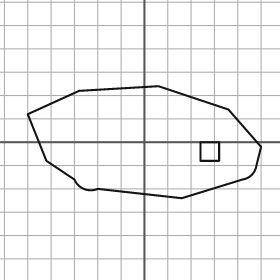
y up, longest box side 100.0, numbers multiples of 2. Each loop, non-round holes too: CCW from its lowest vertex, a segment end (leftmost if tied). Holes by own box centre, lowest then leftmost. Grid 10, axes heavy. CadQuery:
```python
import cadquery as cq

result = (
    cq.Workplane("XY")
    .moveTo(16.0, -24.0)
    .lineTo(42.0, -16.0)
    .threePointArc((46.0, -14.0), (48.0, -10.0))
    .lineTo(50.0, -2.0)
    .lineTo(36.0, 14.0)
    .lineTo(6.0, 24.0)
    .lineTo(-28.0, 22.0)
    .lineTo(-50.0, 12.0)
    .lineTo(-42.0, -8.0)
    .lineTo(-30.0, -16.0)
    .threePointArc((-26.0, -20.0), (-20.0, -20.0))
    .close()
    .moveTo(24.0, -8.0)
    .lineTo(32.0, -8.0)
    .lineTo(32.0, 0.0)
    .lineTo(24.0, 0.0)
    .close()
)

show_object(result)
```